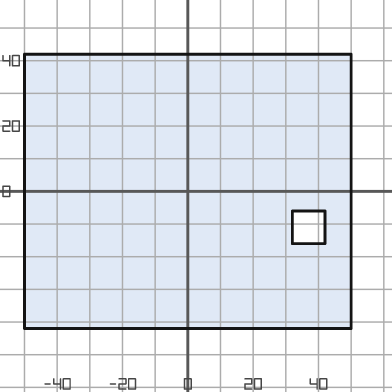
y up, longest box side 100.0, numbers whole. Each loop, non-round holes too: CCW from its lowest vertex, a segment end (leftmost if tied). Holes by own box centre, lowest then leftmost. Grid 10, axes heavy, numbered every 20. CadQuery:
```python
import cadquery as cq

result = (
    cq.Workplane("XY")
    .moveTo(-50.0, -42.0)
    .lineTo(50.0, -42.0)
    .lineTo(50.0, 42.0)
    .lineTo(-50.0, 42.0)
    .close()
    .moveTo(32.0, -16.0)
    .lineTo(42.0, -16.0)
    .lineTo(42.0, -6.0)
    .lineTo(32.0, -6.0)
    .close()
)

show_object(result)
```